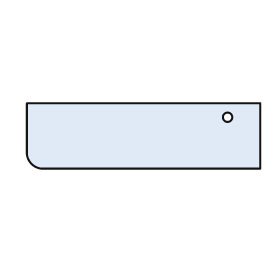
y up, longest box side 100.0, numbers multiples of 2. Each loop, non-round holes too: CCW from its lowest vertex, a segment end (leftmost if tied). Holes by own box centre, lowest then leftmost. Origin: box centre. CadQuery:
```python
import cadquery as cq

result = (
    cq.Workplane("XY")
    .moveTo(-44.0, -14.0)
    .lineTo(50.0, -14.0)
    .lineTo(50.0, 14.0)
    .lineTo(-50.0, 14.0)
    .lineTo(-50.0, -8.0)
    .threePointArc((-48.0, -12.0), (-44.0, -14.0))
    .close()
    .moveTo(36.0, 8.0)
    .circle(2.0)
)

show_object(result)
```